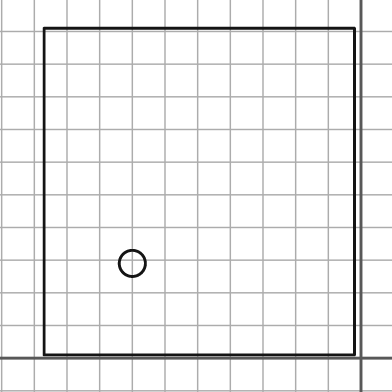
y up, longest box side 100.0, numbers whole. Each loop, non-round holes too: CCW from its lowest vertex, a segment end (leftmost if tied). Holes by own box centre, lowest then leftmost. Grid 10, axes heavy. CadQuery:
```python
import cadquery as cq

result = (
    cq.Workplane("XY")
    .moveTo(-97.0, 1.0)
    .lineTo(-2.0, 1.0)
    .lineTo(-2.0, 101.0)
    .lineTo(-97.0, 101.0)
    .close()
    .moveTo(-70.0, 29.0)
    .circle(4.0)
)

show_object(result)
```